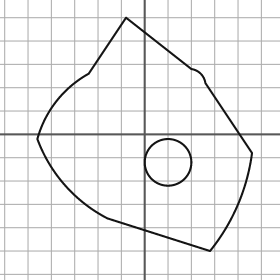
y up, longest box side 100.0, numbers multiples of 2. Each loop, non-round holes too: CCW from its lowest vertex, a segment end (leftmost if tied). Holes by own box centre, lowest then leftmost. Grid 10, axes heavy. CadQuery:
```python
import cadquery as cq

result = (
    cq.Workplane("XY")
    .moveTo(28.0, -50.0)
    .threePointArc((40.0, -30.0), (46.0, -8.0))
    .lineTo(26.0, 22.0)
    .threePointArc((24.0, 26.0), (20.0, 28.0))
    .lineTo(-8.0, 50.0)
    .lineTo(-24.0, 26.0)
    .threePointArc((-38.0, 14.0), (-46.0, -2.0))
    .threePointArc((-34.0, -22.0), (-16.0, -36.0))
    .close()
    .moveTo(10.0, -12.0)
    .circle(10.0)
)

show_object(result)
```